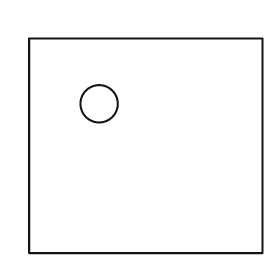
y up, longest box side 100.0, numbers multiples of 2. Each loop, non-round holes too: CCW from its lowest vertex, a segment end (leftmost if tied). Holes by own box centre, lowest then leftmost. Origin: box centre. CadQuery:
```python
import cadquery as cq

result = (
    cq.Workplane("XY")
    .moveTo(-50.0, -46.0)
    .lineTo(50.0, -46.0)
    .lineTo(50.0, 46.0)
    .lineTo(-50.0, 46.0)
    .close()
    .moveTo(-20.0, 18.0)
    .circle(8.0)
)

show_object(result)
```